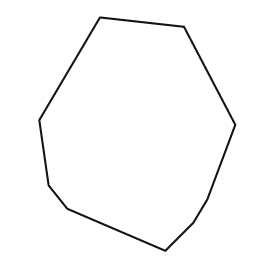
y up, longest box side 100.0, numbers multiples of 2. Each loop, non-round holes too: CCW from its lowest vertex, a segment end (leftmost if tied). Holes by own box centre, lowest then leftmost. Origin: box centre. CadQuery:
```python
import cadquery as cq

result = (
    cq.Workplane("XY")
    .moveTo(12.0, -50.0)
    .lineTo(24.0, -38.0)
    .lineTo(30.0, -28.0)
    .lineTo(42.0, 4.0)
    .lineTo(20.0, 46.0)
    .lineTo(-16.0, 50.0)
    .lineTo(-42.0, 6.0)
    .lineTo(-38.0, -22.0)
    .lineTo(-30.0, -32.0)
    .close()
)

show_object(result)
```